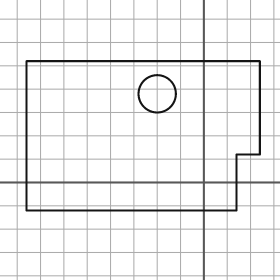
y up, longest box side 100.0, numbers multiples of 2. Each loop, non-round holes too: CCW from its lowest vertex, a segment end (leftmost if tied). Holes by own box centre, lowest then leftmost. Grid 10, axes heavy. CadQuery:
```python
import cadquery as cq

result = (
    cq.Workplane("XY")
    .moveTo(-76.0, -12.0)
    .lineTo(14.0, -12.0)
    .lineTo(14.0, 12.0)
    .lineTo(24.0, 12.0)
    .lineTo(24.0, 52.0)
    .lineTo(-76.0, 52.0)
    .close()
    .moveTo(-20.0, 38.0)
    .circle(8.0)
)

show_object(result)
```